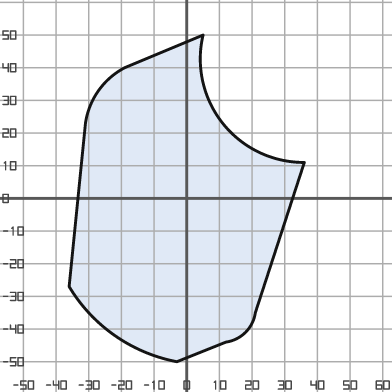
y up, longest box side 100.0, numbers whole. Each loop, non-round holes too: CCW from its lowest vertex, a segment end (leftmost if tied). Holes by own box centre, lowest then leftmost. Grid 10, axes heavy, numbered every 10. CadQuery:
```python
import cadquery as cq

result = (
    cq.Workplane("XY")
    .moveTo(-3.0, -50.0)
    .lineTo(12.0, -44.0)
    .threePointArc((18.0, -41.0), (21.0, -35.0))
    .lineTo(36.0, 11.0)
    .threePointArc((11.0, 23.0), (5.0, 50.0))
    .lineTo(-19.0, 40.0)
    .threePointArc((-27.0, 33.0), (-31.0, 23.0))
    .lineTo(-36.0, -27.0)
    .threePointArc((-22.0, -42.0), (-3.0, -50.0))
    .close()
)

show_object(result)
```